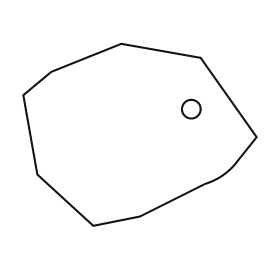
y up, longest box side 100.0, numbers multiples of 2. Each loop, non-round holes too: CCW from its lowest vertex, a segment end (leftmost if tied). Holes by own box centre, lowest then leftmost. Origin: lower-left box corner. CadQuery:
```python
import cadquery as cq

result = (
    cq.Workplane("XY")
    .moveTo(30.0, 0.0)
    .lineTo(50.0, 4.0)
    .lineTo(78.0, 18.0)
    .threePointArc((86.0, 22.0), (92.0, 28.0))
    .lineTo(100.0, 38.0)
    .lineTo(76.0, 72.0)
    .lineTo(42.0, 78.0)
    .lineTo(12.0, 66.0)
    .lineTo(0.0, 56.0)
    .lineTo(6.0, 22.0)
    .close()
    .moveTo(72.0, 50.0)
    .circle(4.0)
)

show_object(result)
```